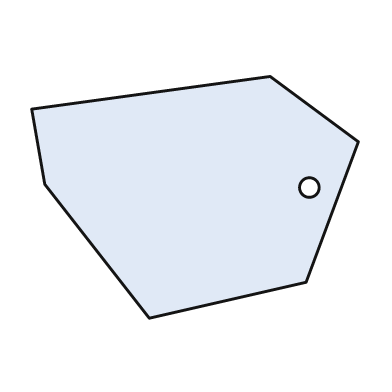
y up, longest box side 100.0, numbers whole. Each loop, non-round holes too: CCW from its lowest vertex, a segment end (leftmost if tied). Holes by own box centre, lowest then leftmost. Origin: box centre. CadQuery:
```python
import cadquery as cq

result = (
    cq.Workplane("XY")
    .moveTo(-14.0, -37.0)
    .lineTo(34.0, -26.0)
    .lineTo(50.0, 17.0)
    .lineTo(23.0, 37.0)
    .lineTo(-50.0, 27.0)
    .lineTo(-46.0, 4.0)
    .close()
    .moveTo(35.0, 3.0)
    .circle(3.0)
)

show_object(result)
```